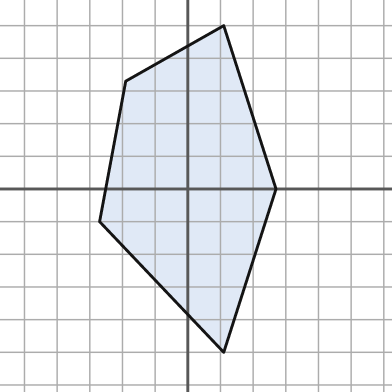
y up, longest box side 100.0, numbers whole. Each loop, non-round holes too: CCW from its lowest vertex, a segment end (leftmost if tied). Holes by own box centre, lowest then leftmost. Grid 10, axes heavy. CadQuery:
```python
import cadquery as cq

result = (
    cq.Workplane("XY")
    .moveTo(11.0, -50.0)
    .lineTo(27.0, 0.0)
    .lineTo(11.0, 50.0)
    .lineTo(-19.0, 33.0)
    .lineTo(-27.0, -10.0)
    .close()
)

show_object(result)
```